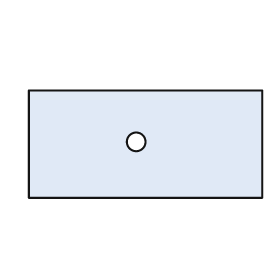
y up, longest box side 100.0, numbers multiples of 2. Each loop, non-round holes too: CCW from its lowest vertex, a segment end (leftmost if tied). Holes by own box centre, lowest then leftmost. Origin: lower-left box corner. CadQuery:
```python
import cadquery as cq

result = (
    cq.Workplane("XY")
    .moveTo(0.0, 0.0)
    .lineTo(100.0, 0.0)
    .lineTo(100.0, 46.0)
    .lineTo(0.0, 46.0)
    .close()
    .moveTo(46.0, 24.0)
    .circle(4.0)
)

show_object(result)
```